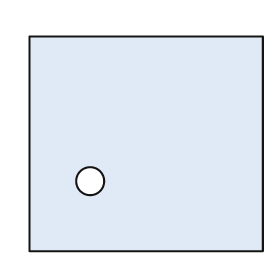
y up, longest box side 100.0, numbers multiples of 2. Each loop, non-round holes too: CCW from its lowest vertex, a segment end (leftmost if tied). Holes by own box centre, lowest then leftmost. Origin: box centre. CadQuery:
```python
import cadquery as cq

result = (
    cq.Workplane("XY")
    .moveTo(-50.0, -46.0)
    .lineTo(50.0, -46.0)
    .lineTo(50.0, 46.0)
    .lineTo(-50.0, 46.0)
    .close()
    .moveTo(-24.0, -16.0)
    .circle(6.0)
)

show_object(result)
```